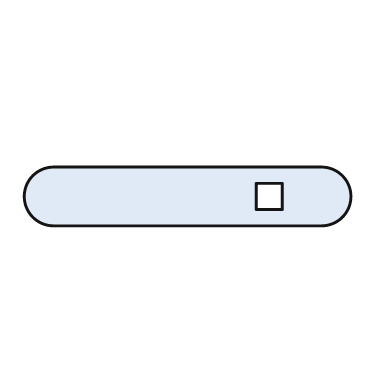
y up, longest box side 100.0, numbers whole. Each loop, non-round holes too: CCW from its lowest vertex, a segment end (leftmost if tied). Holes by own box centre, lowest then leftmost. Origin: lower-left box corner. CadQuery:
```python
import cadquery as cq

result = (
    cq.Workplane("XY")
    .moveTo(9.0, 0.0)
    .lineTo(91.0, 0.0)
    .threePointArc((100.0, 9.0), (91.0, 18.0))
    .lineTo(9.0, 18.0)
    .threePointArc((0.0, 9.0), (9.0, 0.0))
    .close()
    .moveTo(71.0, 5.0)
    .lineTo(79.0, 5.0)
    .lineTo(79.0, 13.0)
    .lineTo(71.0, 13.0)
    .close()
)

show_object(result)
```